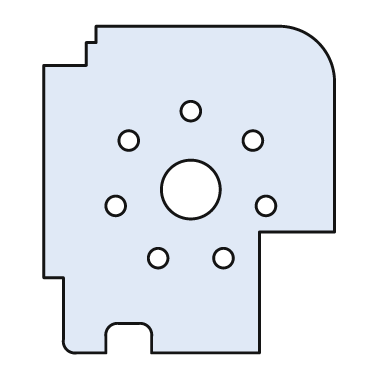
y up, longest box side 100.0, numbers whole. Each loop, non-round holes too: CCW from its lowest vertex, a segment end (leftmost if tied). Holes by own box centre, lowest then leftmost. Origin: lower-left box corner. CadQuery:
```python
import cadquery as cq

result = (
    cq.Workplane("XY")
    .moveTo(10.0, 0.0)
    .lineTo(19.0, 0.0)
    .lineTo(19.0, 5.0)
    .threePointArc((20.0, 8.0), (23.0, 9.0))
    .lineTo(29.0, 9.0)
    .threePointArc((32.0, 8.0), (33.0, 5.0))
    .lineTo(33.0, 0.0)
    .lineTo(66.0, 0.0)
    .lineTo(66.0, 37.0)
    .lineTo(89.0, 37.0)
    .lineTo(89.0, 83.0)
    .threePointArc((84.0, 95.0), (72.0, 100.0))
    .lineTo(16.0, 100.0)
    .lineTo(16.0, 95.0)
    .lineTo(13.0, 95.0)
    .lineTo(13.0, 88.0)
    .lineTo(0.0, 88.0)
    .lineTo(0.0, 23.0)
    .lineTo(6.0, 23.0)
    .lineTo(6.0, 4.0)
    .threePointArc((7.0, 1.0), (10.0, 0.0))
    .close()
    .moveTo(35.0, 29.0)
    .circle(3.0)
    .moveTo(55.0, 29.0)
    .circle(3.0)
    .moveTo(22.0, 45.0)
    .circle(3.0)
    .moveTo(68.0, 45.0)
    .circle(3.0)
    .moveTo(45.0, 50.0)
    .circle(9.0)
    .moveTo(26.0, 65.0)
    .circle(3.0)
    .moveTo(64.0, 65.0)
    .circle(3.0)
    .moveTo(45.0, 74.0)
    .circle(3.0)
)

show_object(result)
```